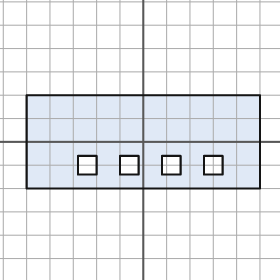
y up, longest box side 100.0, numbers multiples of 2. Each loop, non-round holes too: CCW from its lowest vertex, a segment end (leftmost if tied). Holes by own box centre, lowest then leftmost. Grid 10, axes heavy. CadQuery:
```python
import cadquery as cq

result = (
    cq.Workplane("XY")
    .moveTo(-50.0, -20.0)
    .lineTo(50.0, -20.0)
    .lineTo(50.0, 20.0)
    .lineTo(-50.0, 20.0)
    .close()
    .moveTo(-28.0, -14.0)
    .lineTo(-20.0, -14.0)
    .lineTo(-20.0, -6.0)
    .lineTo(-28.0, -6.0)
    .close()
    .moveTo(-10.0, -14.0)
    .lineTo(-2.0, -14.0)
    .lineTo(-2.0, -6.0)
    .lineTo(-10.0, -6.0)
    .close()
    .moveTo(8.0, -14.0)
    .lineTo(16.0, -14.0)
    .lineTo(16.0, -6.0)
    .lineTo(8.0, -6.0)
    .close()
    .moveTo(26.0, -14.0)
    .lineTo(34.0, -14.0)
    .lineTo(34.0, -6.0)
    .lineTo(26.0, -6.0)
    .close()
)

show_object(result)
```